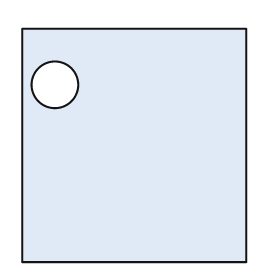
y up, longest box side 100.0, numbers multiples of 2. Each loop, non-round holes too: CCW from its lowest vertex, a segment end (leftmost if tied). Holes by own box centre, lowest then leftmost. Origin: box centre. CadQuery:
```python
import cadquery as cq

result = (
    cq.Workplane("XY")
    .moveTo(-48.0, -50.0)
    .lineTo(48.0, -50.0)
    .lineTo(48.0, 50.0)
    .lineTo(-48.0, 50.0)
    .close()
    .moveTo(-34.0, 26.0)
    .circle(10.0)
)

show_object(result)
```